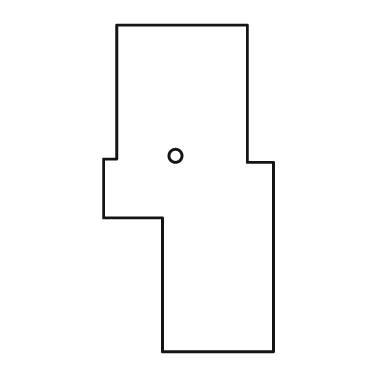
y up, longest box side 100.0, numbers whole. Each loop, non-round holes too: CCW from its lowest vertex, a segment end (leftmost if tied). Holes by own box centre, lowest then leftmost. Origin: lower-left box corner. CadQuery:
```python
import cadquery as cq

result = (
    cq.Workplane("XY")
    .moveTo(18.0, 0.0)
    .lineTo(52.0, 0.0)
    .lineTo(52.0, 58.0)
    .lineTo(44.0, 58.0)
    .lineTo(44.0, 100.0)
    .lineTo(4.0, 100.0)
    .lineTo(4.0, 59.0)
    .lineTo(0.0, 59.0)
    .lineTo(0.0, 41.0)
    .lineTo(18.0, 41.0)
    .close()
    .moveTo(22.0, 60.0)
    .circle(2.0)
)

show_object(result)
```